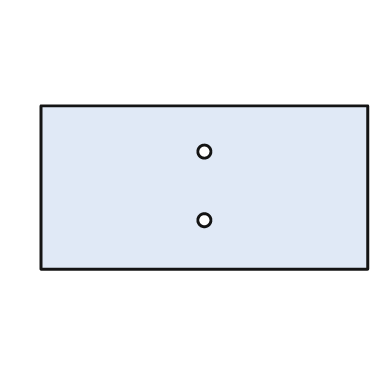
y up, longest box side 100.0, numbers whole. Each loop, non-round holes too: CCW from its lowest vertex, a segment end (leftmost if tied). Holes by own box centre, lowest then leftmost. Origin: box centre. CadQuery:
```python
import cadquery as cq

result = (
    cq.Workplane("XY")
    .moveTo(-50.0, -25.0)
    .lineTo(50.0, -25.0)
    .lineTo(50.0, 25.0)
    .lineTo(-50.0, 25.0)
    .close()
    .moveTo(0.0, -10.0)
    .circle(2.0)
    .moveTo(0.0, 11.0)
    .circle(2.0)
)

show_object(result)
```